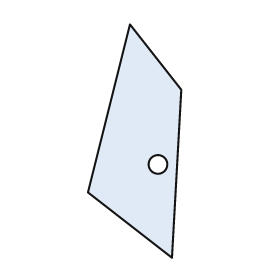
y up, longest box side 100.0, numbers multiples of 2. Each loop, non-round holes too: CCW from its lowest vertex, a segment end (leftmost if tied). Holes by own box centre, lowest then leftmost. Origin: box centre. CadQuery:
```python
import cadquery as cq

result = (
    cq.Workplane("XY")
    .moveTo(16.0, -50.0)
    .lineTo(20.0, 22.0)
    .lineTo(-2.0, 50.0)
    .lineTo(-20.0, -22.0)
    .close()
    .moveTo(10.0, -10.0)
    .circle(4.0)
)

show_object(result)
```